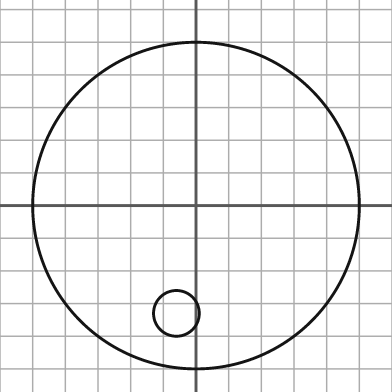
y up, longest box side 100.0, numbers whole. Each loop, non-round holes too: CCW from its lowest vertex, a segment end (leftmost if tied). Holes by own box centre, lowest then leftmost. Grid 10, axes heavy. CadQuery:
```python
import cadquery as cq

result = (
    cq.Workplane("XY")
    .moveTo(0.0, 0.0)
    .circle(50.0)
    .moveTo(-6.0, -33.0)
    .circle(7.0)
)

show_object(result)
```